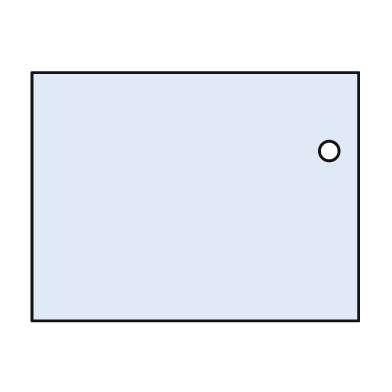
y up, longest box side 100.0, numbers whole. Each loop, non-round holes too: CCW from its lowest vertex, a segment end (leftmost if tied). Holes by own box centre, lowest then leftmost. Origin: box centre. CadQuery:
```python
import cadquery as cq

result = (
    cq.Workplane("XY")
    .moveTo(-50.0, -38.0)
    .lineTo(50.0, -38.0)
    .lineTo(50.0, 38.0)
    .lineTo(-50.0, 38.0)
    .close()
    .moveTo(41.0, 14.0)
    .circle(3.0)
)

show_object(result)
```